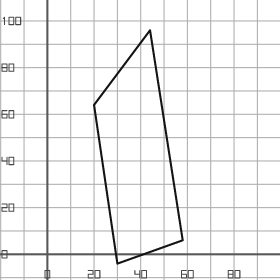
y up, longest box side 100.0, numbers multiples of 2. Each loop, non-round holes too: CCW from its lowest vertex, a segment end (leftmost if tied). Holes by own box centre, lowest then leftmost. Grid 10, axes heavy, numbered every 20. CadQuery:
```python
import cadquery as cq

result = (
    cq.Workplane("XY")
    .moveTo(30.0, -4.0)
    .lineTo(58.0, 6.0)
    .lineTo(44.0, 96.0)
    .lineTo(20.0, 64.0)
    .close()
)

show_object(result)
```